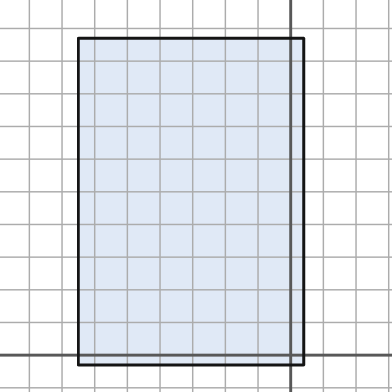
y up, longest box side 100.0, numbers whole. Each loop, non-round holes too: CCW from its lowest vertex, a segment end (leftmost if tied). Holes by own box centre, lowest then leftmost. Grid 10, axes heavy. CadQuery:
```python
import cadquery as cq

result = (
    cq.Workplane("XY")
    .moveTo(-65.0, -3.0)
    .lineTo(4.0, -3.0)
    .lineTo(4.0, 97.0)
    .lineTo(-65.0, 97.0)
    .close()
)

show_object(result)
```